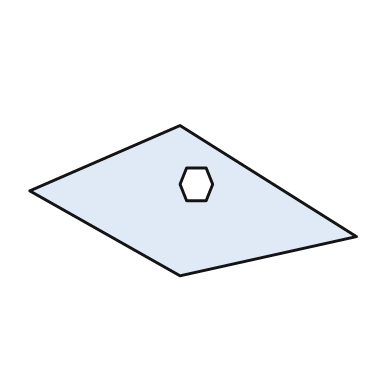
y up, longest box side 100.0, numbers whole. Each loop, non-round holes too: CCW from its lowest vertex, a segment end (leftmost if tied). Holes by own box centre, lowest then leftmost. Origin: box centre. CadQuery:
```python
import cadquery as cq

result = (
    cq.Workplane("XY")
    .moveTo(-4.0, -23.0)
    .lineTo(50.0, -11.0)
    .lineTo(-4.0, 23.0)
    .lineTo(-50.0, 3.0)
    .close()
    .moveTo(-2.0, 0.0)
    .lineTo(4.0, 0.0)
    .lineTo(6.0, 5.0)
    .lineTo(4.0, 10.0)
    .lineTo(-2.0, 10.0)
    .lineTo(-4.0, 5.0)
    .close()
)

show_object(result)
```